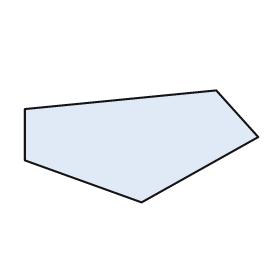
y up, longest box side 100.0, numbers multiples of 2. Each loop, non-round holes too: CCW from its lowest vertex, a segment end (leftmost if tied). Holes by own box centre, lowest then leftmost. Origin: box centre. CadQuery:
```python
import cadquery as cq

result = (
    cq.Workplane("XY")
    .moveTo(0.0, -24.0)
    .lineTo(50.0, 4.0)
    .lineTo(32.0, 24.0)
    .lineTo(-50.0, 16.0)
    .lineTo(-50.0, -6.0)
    .close()
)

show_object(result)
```